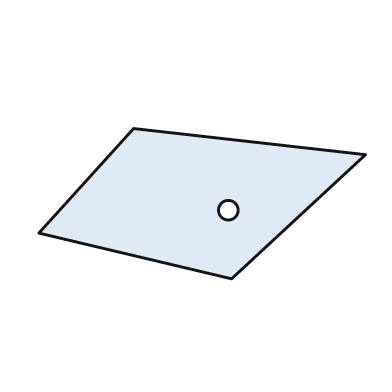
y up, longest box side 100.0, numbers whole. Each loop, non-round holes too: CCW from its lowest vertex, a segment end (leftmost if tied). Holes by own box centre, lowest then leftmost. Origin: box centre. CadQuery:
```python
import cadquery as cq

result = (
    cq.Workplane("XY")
    .moveTo(9.0, -23.0)
    .lineTo(50.0, 15.0)
    .lineTo(-21.0, 23.0)
    .lineTo(-50.0, -9.0)
    .close()
    .moveTo(8.0, -2.0)
    .circle(3.0)
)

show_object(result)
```